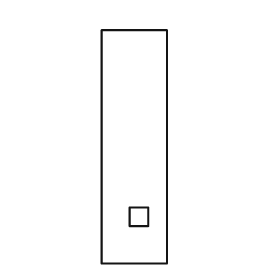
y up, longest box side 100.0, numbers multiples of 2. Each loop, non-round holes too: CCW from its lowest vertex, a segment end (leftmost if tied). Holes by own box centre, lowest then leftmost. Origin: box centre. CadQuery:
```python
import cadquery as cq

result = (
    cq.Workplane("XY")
    .moveTo(-14.0, -50.0)
    .lineTo(14.0, -50.0)
    .lineTo(14.0, 50.0)
    .lineTo(-14.0, 50.0)
    .close()
    .moveTo(-2.0, -34.0)
    .lineTo(6.0, -34.0)
    .lineTo(6.0, -26.0)
    .lineTo(-2.0, -26.0)
    .close()
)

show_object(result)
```